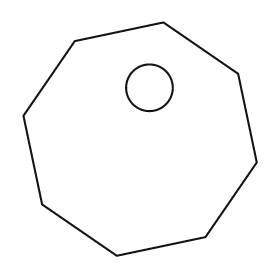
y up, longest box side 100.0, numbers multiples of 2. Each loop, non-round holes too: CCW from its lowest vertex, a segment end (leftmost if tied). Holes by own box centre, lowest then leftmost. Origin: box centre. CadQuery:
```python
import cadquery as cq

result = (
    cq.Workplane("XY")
    .moveTo(-10.0, -50.0)
    .lineTo(28.0, -42.0)
    .lineTo(50.0, -10.0)
    .lineTo(42.0, 28.0)
    .lineTo(10.0, 50.0)
    .lineTo(-28.0, 42.0)
    .lineTo(-50.0, 10.0)
    .lineTo(-42.0, -28.0)
    .close()
    .moveTo(4.0, 22.0)
    .circle(10.0)
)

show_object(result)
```